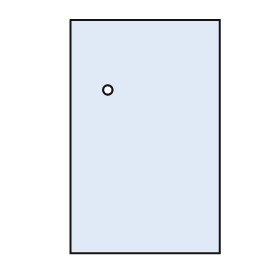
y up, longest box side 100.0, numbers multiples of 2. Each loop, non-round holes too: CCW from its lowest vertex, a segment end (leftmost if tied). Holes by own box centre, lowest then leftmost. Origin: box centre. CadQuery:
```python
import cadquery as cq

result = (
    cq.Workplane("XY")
    .moveTo(-32.0, -50.0)
    .lineTo(32.0, -50.0)
    .lineTo(32.0, 50.0)
    .lineTo(-32.0, 50.0)
    .close()
    .moveTo(-16.0, 20.0)
    .circle(2.0)
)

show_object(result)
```